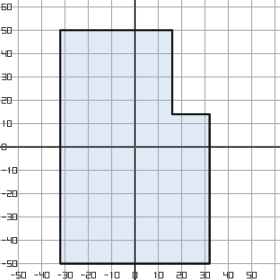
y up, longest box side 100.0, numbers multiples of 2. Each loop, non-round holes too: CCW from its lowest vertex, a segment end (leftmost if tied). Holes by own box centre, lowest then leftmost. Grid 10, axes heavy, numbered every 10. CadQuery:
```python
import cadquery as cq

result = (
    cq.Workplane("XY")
    .moveTo(-32.0, -50.0)
    .lineTo(32.0, -50.0)
    .lineTo(32.0, 14.0)
    .lineTo(16.0, 14.0)
    .lineTo(16.0, 50.0)
    .lineTo(-32.0, 50.0)
    .close()
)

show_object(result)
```